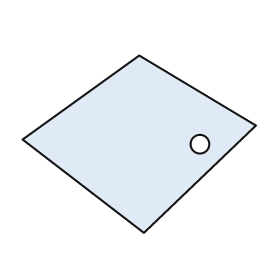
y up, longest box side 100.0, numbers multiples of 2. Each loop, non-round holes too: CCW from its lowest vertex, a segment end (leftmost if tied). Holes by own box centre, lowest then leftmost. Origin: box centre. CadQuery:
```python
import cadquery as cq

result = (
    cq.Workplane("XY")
    .moveTo(2.0, -38.0)
    .lineTo(50.0, 8.0)
    .lineTo(0.0, 38.0)
    .lineTo(-50.0, 2.0)
    .close()
    .moveTo(26.0, 0.0)
    .circle(4.0)
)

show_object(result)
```